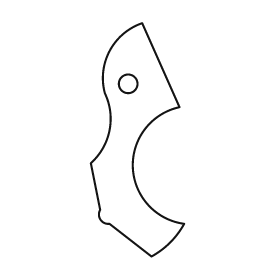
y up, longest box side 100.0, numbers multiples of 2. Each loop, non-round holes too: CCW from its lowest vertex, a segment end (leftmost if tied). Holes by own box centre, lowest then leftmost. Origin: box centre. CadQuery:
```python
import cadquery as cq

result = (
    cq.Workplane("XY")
    .moveTo(6.0, -50.0)
    .threePointArc((14.0, -44.0), (20.0, -36.0))
    .threePointArc((-2.0, -12.0), (18.0, 14.0))
    .lineTo(2.0, 50.0)
    .threePointArc((-12.0, 38.0), (-14.0, 20.0))
    .threePointArc((-12.0, 4.0), (-20.0, -10.0))
    .lineTo(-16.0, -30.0)
    .threePointArc((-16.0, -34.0), (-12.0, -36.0))
    .close()
    .moveTo(-4.0, 24.0)
    .circle(4.0)
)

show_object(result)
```